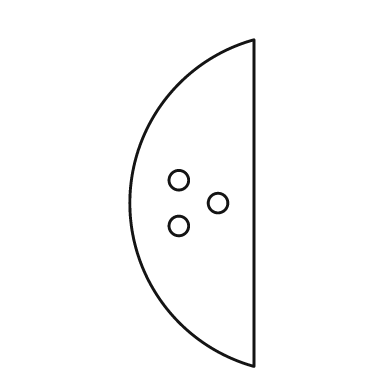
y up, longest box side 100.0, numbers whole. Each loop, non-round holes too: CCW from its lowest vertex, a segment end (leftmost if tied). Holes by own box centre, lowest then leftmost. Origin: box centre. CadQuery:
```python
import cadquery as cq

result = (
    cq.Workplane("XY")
    .moveTo(19.0, -50.0)
    .lineTo(19.0, 50.0)
    .threePointArc((-19.0, 0.0), (19.0, -50.0))
    .close()
    .moveTo(-4.0, -7.0)
    .circle(3.0)
    .moveTo(8.0, 0.0)
    .circle(3.0)
    .moveTo(-4.0, 7.0)
    .circle(3.0)
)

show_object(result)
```